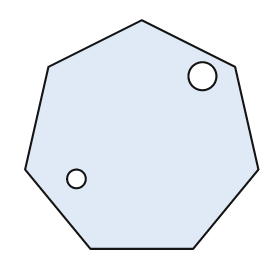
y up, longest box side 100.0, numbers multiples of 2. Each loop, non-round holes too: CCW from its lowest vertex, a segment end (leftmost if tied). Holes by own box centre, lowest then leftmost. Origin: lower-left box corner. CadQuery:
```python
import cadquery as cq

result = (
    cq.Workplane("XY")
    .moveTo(28.0, 0.0)
    .lineTo(72.0, 0.0)
    .lineTo(100.0, 34.0)
    .lineTo(90.0, 78.0)
    .lineTo(50.0, 98.0)
    .lineTo(10.0, 78.0)
    .lineTo(0.0, 34.0)
    .close()
    .moveTo(22.0, 30.0)
    .circle(4.0)
    .moveTo(76.0, 74.0)
    .circle(6.0)
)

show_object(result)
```